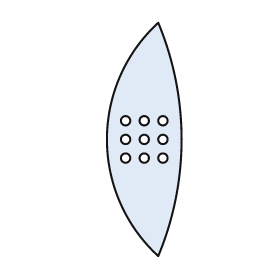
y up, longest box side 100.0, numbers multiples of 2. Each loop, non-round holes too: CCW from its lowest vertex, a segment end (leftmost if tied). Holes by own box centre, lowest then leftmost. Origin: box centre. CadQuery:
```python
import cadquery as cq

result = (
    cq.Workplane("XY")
    .moveTo(6.0, -50.0)
    .threePointArc((16.0, 0.0), (6.0, 50.0))
    .threePointArc((-16.0, 0.0), (6.0, -50.0))
    .close()
    .moveTo(-8.0, -8.0)
    .circle(2.0)
    .moveTo(0.0, -8.0)
    .circle(2.0)
    .moveTo(8.0, -8.0)
    .circle(2.0)
    .moveTo(-8.0, 0.0)
    .circle(2.0)
    .moveTo(0.0, 0.0)
    .circle(2.0)
    .moveTo(8.0, 0.0)
    .circle(2.0)
    .moveTo(-8.0, 8.0)
    .circle(2.0)
    .moveTo(0.0, 8.0)
    .circle(2.0)
    .moveTo(8.0, 8.0)
    .circle(2.0)
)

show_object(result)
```